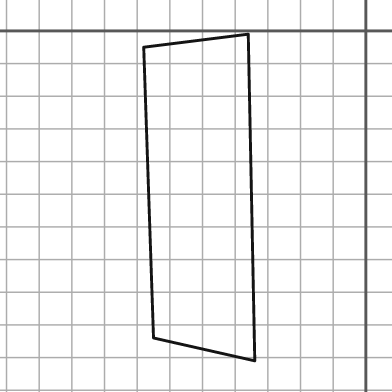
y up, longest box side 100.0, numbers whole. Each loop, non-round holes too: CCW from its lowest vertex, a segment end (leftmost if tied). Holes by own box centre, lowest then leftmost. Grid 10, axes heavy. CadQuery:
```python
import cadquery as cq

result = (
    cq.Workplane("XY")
    .moveTo(-34.0, -101.0)
    .lineTo(-36.0, -1.0)
    .lineTo(-68.0, -5.0)
    .lineTo(-65.0, -94.0)
    .close()
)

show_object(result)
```